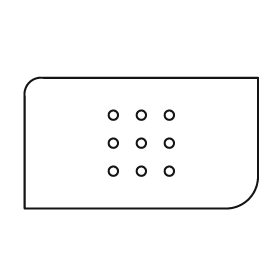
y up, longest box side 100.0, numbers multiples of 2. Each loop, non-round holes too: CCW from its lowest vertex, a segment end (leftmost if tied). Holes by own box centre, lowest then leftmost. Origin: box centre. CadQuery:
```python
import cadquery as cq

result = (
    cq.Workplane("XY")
    .moveTo(-50.0, -28.0)
    .lineTo(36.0, -28.0)
    .threePointArc((46.0, -24.0), (50.0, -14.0))
    .lineTo(50.0, 28.0)
    .lineTo(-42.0, 28.0)
    .threePointArc((-48.0, 26.0), (-50.0, 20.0))
    .close()
    .moveTo(-12.0, -12.0)
    .circle(2.0)
    .moveTo(0.0, -12.0)
    .circle(2.0)
    .moveTo(12.0, -12.0)
    .circle(2.0)
    .moveTo(-12.0, 0.0)
    .circle(2.0)
    .moveTo(0.0, 0.0)
    .circle(2.0)
    .moveTo(12.0, 0.0)
    .circle(2.0)
    .moveTo(-12.0, 12.0)
    .circle(2.0)
    .moveTo(0.0, 12.0)
    .circle(2.0)
    .moveTo(12.0, 12.0)
    .circle(2.0)
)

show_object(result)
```